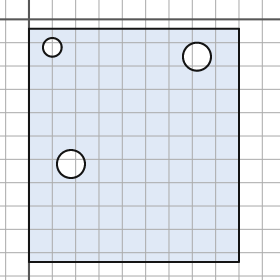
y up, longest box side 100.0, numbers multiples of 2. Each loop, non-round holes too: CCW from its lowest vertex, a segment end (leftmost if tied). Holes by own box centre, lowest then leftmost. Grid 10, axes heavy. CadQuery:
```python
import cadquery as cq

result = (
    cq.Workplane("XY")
    .moveTo(0.0, -104.0)
    .lineTo(90.0, -104.0)
    .lineTo(90.0, -4.0)
    .lineTo(0.0, -4.0)
    .close()
    .moveTo(18.0, -62.0)
    .circle(6.0)
    .moveTo(72.0, -16.0)
    .circle(6.0)
    .moveTo(10.0, -12.0)
    .circle(4.0)
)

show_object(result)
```